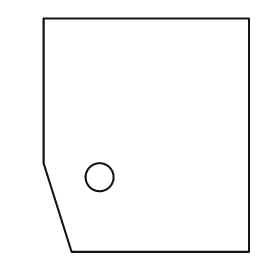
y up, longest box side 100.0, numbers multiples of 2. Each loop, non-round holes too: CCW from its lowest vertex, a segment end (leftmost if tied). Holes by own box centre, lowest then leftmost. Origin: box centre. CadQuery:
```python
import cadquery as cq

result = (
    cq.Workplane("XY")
    .moveTo(-32.0, -50.0)
    .lineTo(44.0, -50.0)
    .lineTo(44.0, 50.0)
    .lineTo(-44.0, 50.0)
    .lineTo(-44.0, -12.0)
    .close()
    .moveTo(-20.0, -18.0)
    .circle(6.0)
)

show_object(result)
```